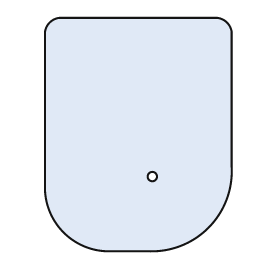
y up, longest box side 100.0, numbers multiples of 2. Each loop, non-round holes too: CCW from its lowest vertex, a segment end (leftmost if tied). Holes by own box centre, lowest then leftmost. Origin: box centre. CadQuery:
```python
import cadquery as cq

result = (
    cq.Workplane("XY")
    .moveTo(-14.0, -50.0)
    .lineTo(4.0, -50.0)
    .threePointArc((30.0, -40.0), (40.0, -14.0))
    .lineTo(40.0, 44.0)
    .threePointArc((38.0, 48.0), (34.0, 50.0))
    .lineTo(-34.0, 50.0)
    .threePointArc((-38.0, 48.0), (-40.0, 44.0))
    .lineTo(-40.0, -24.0)
    .threePointArc((-32.0, -42.0), (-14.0, -50.0))
    .close()
    .moveTo(6.0, -18.0)
    .circle(2.0)
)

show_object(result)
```